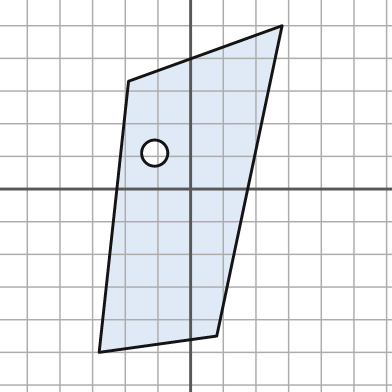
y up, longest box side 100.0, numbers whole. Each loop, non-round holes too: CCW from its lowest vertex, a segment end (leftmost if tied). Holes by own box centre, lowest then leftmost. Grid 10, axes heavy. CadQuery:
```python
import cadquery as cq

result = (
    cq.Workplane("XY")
    .moveTo(-28.0, -50.0)
    .lineTo(8.0, -45.0)
    .lineTo(28.0, 50.0)
    .lineTo(-19.0, 33.0)
    .close()
    .moveTo(-11.0, 11.0)
    .circle(4.0)
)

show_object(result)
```